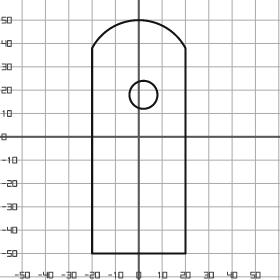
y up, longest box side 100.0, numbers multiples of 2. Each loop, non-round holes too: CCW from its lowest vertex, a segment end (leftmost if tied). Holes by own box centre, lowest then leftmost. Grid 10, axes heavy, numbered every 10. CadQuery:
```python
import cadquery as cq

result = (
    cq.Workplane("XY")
    .moveTo(-20.0, -50.0)
    .lineTo(20.0, -50.0)
    .lineTo(20.0, 38.0)
    .threePointArc((0.0, 50.0), (-20.0, 38.0))
    .close()
    .moveTo(2.0, 18.0)
    .circle(6.0)
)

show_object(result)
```